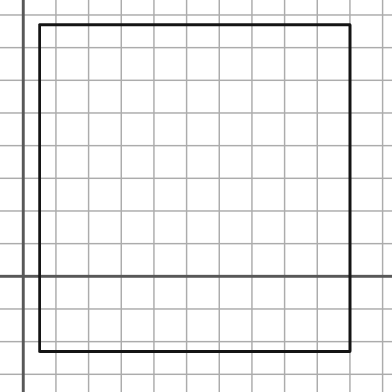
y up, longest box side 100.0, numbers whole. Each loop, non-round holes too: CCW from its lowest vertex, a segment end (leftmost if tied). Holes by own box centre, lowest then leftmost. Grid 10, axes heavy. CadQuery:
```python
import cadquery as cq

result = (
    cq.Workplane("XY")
    .moveTo(5.0, -23.0)
    .lineTo(100.0, -23.0)
    .lineTo(100.0, 77.0)
    .lineTo(5.0, 77.0)
    .close()
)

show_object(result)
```